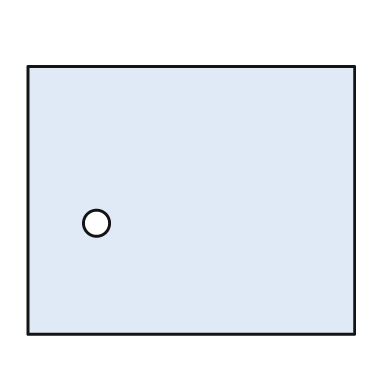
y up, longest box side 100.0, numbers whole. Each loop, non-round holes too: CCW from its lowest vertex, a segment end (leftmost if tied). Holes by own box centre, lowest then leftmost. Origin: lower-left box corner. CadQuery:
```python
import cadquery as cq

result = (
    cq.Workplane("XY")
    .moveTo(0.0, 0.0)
    .lineTo(100.0, 0.0)
    .lineTo(100.0, 82.0)
    .lineTo(0.0, 82.0)
    .close()
    .moveTo(21.0, 34.0)
    .circle(4.0)
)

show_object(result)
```